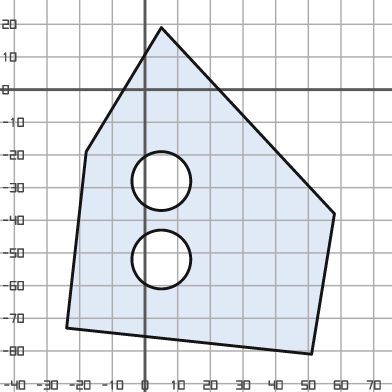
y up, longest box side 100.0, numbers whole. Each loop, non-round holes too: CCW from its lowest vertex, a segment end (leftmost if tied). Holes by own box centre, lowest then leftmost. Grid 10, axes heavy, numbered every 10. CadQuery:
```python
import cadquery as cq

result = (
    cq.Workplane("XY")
    .moveTo(51.0, -81.0)
    .lineTo(58.0, -38.0)
    .lineTo(5.0, 19.0)
    .lineTo(-18.0, -19.0)
    .lineTo(-24.0, -73.0)
    .close()
    .moveTo(5.0, -52.0)
    .circle(9.0)
    .moveTo(5.0, -28.0)
    .circle(9.0)
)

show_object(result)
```